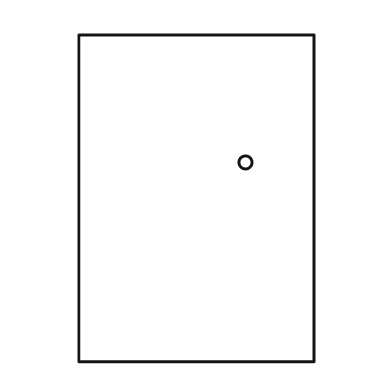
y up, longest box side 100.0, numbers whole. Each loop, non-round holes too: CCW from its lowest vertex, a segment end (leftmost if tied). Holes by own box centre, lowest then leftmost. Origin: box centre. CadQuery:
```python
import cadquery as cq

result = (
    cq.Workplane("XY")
    .moveTo(-36.0, -50.0)
    .lineTo(36.0, -50.0)
    .lineTo(36.0, 50.0)
    .lineTo(-36.0, 50.0)
    .close()
    .moveTo(15.0, 11.0)
    .circle(2.0)
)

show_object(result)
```